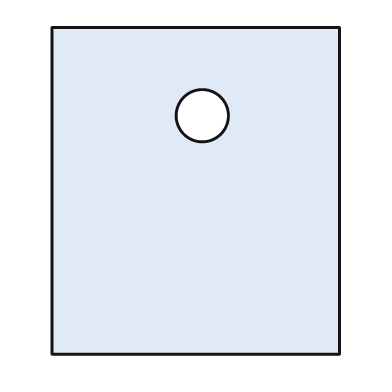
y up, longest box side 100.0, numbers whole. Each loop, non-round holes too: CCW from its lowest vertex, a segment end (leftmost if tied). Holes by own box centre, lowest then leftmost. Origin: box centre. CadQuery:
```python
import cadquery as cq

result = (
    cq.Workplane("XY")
    .moveTo(-44.0, -50.0)
    .lineTo(44.0, -50.0)
    .lineTo(44.0, 50.0)
    .lineTo(-44.0, 50.0)
    .close()
    .moveTo(2.0, 23.0)
    .circle(8.0)
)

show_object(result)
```